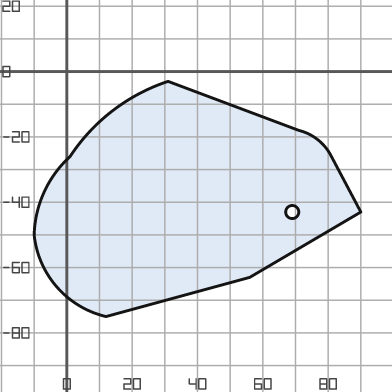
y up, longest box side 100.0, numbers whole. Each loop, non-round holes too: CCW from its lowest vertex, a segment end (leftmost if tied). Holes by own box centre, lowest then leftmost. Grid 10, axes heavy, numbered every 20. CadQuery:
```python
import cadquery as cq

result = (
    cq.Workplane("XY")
    .moveTo(12.0, -75.0)
    .lineTo(56.0, -63.0)
    .lineTo(90.0, -43.0)
    .lineTo(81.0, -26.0)
    .threePointArc((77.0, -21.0), (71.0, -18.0))
    .lineTo(31.0, -3.0)
    .threePointArc((14.0, -12.0), (1.0, -26.0))
    .threePointArc((-7.0, -37.0), (-10.0, -50.0))
    .threePointArc((-3.0, -66.0), (12.0, -75.0))
    .close()
    .moveTo(69.0, -43.0)
    .circle(2.0)
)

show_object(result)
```